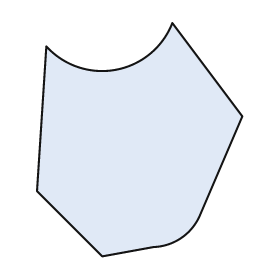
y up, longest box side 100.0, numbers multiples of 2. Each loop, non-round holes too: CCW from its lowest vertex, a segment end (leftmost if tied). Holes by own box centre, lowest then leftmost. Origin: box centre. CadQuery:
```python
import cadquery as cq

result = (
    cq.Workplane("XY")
    .moveTo(-16.0, -50.0)
    .lineTo(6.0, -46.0)
    .threePointArc((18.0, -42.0), (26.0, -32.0))
    .lineTo(44.0, 10.0)
    .lineTo(14.0, 50.0)
    .threePointArc((-10.0, 30.0), (-40.0, 40.0))
    .lineTo(-44.0, -22.0)
    .close()
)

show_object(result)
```